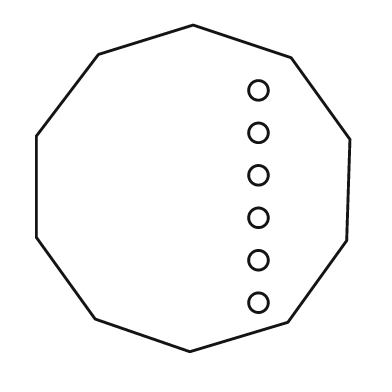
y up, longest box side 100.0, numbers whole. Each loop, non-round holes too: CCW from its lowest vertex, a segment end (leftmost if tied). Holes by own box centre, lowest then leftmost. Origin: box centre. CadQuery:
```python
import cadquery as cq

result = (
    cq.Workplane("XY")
    .moveTo(-1.0, -50.0)
    .lineTo(29.0, -41.0)
    .lineTo(47.0, -16.0)
    .lineTo(48.0, 15.0)
    .lineTo(30.0, 40.0)
    .lineTo(0.0, 50.0)
    .lineTo(-29.0, 41.0)
    .lineTo(-48.0, 16.0)
    .lineTo(-48.0, -15.0)
    .lineTo(-30.0, -40.0)
    .close()
    .moveTo(20.0, -35.0)
    .circle(3.0)
    .moveTo(20.0, -22.0)
    .circle(3.0)
    .moveTo(20.0, -9.0)
    .circle(3.0)
    .moveTo(20.0, 4.0)
    .circle(3.0)
    .moveTo(20.0, 17.0)
    .circle(3.0)
    .moveTo(20.0, 30.0)
    .circle(3.0)
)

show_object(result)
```